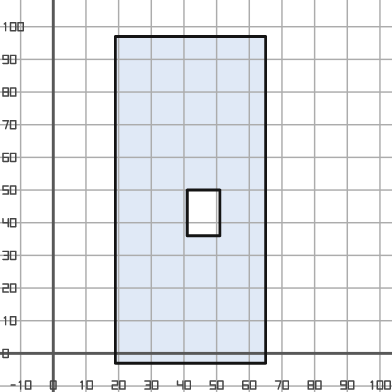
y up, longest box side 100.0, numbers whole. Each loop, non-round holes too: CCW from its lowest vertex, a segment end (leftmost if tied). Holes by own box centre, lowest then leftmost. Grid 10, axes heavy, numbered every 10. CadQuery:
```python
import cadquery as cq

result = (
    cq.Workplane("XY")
    .moveTo(19.0, -3.0)
    .lineTo(65.0, -3.0)
    .lineTo(65.0, 97.0)
    .lineTo(19.0, 97.0)
    .close()
    .moveTo(41.0, 36.0)
    .lineTo(51.0, 36.0)
    .lineTo(51.0, 50.0)
    .lineTo(41.0, 50.0)
    .close()
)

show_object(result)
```